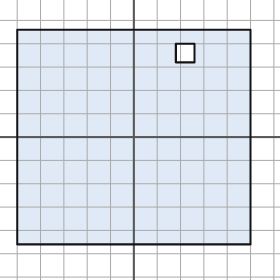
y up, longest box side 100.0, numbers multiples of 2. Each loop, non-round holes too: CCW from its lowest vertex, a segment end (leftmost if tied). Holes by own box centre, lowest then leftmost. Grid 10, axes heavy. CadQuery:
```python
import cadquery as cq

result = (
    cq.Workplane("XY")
    .moveTo(-50.0, -46.0)
    .lineTo(50.0, -46.0)
    .lineTo(50.0, 46.0)
    .lineTo(-50.0, 46.0)
    .close()
    .moveTo(18.0, 32.0)
    .lineTo(26.0, 32.0)
    .lineTo(26.0, 40.0)
    .lineTo(18.0, 40.0)
    .close()
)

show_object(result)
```